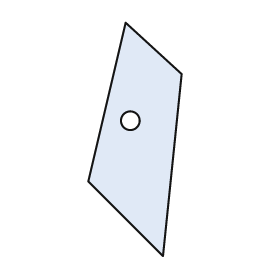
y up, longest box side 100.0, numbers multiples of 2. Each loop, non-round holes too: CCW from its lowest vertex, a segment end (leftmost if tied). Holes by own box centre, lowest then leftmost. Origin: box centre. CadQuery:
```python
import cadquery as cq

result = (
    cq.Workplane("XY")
    .moveTo(12.0, -50.0)
    .lineTo(20.0, 28.0)
    .lineTo(-4.0, 50.0)
    .lineTo(-20.0, -18.0)
    .close()
    .moveTo(-2.0, 8.0)
    .circle(4.0)
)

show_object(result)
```